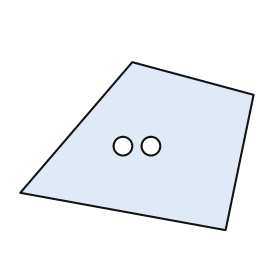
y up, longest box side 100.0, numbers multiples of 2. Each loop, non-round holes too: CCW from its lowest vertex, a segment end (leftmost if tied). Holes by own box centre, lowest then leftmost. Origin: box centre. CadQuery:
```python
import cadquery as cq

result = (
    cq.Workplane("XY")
    .moveTo(38.0, -36.0)
    .lineTo(50.0, 22.0)
    .lineTo(-2.0, 36.0)
    .lineTo(-50.0, -20.0)
    .close()
    .moveTo(-6.0, 0.0)
    .circle(4.0)
    .moveTo(6.0, 0.0)
    .circle(4.0)
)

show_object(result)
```